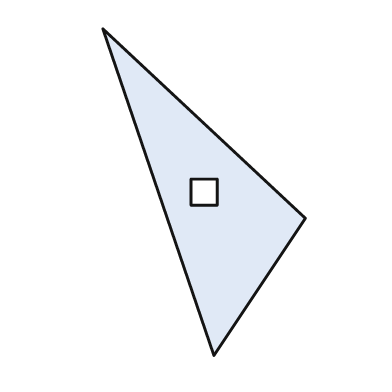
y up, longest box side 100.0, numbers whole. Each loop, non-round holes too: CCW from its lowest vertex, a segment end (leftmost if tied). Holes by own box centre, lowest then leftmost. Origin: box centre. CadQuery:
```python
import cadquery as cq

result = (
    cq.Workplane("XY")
    .moveTo(3.0, -50.0)
    .lineTo(31.0, -8.0)
    .lineTo(-31.0, 50.0)
    .close()
    .moveTo(-4.0, -4.0)
    .lineTo(4.0, -4.0)
    .lineTo(4.0, 4.0)
    .lineTo(-4.0, 4.0)
    .close()
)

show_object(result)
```